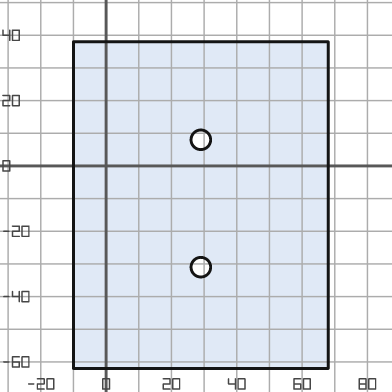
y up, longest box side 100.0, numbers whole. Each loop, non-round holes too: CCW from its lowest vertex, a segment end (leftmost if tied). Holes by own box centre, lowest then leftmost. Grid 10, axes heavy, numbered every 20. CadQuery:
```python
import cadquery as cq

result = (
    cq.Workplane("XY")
    .moveTo(-10.0, -62.0)
    .lineTo(68.0, -62.0)
    .lineTo(68.0, 38.0)
    .lineTo(-10.0, 38.0)
    .close()
    .moveTo(29.0, -31.0)
    .circle(3.0)
    .moveTo(29.0, 8.0)
    .circle(3.0)
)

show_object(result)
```